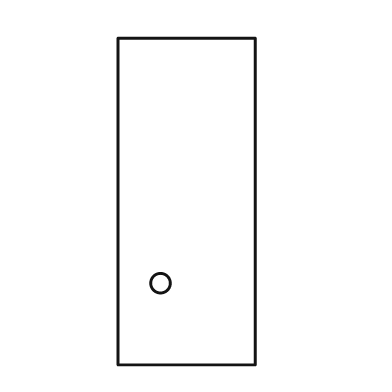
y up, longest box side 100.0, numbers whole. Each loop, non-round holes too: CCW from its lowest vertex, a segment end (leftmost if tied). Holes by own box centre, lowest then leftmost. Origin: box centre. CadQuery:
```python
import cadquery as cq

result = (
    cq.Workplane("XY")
    .moveTo(-21.0, -50.0)
    .lineTo(21.0, -50.0)
    .lineTo(21.0, 50.0)
    .lineTo(-21.0, 50.0)
    .close()
    .moveTo(-8.0, -25.0)
    .circle(3.0)
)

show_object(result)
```